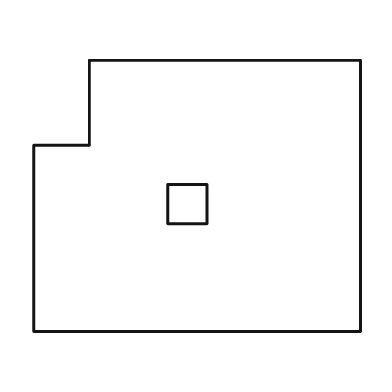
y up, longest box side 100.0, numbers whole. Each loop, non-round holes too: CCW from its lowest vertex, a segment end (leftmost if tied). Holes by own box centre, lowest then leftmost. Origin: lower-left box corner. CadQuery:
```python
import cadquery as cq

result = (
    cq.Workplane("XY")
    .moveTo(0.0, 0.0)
    .lineTo(100.0, 0.0)
    .lineTo(100.0, 83.0)
    .lineTo(17.0, 83.0)
    .lineTo(17.0, 57.0)
    .lineTo(0.0, 57.0)
    .close()
    .moveTo(41.0, 33.0)
    .lineTo(53.0, 33.0)
    .lineTo(53.0, 45.0)
    .lineTo(41.0, 45.0)
    .close()
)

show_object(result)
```